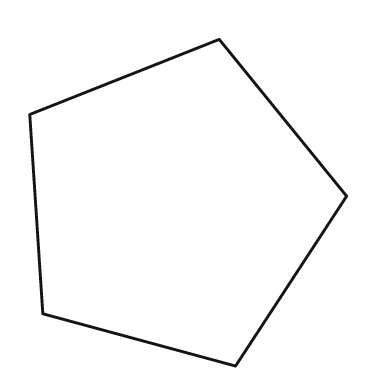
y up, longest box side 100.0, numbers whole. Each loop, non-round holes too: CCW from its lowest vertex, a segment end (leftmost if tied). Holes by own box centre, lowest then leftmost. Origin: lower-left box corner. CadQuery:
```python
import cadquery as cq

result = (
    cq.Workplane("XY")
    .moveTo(63.0, 0.0)
    .lineTo(97.0, 52.0)
    .lineTo(58.0, 100.0)
    .lineTo(0.0, 77.0)
    .lineTo(4.0, 16.0)
    .close()
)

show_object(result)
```